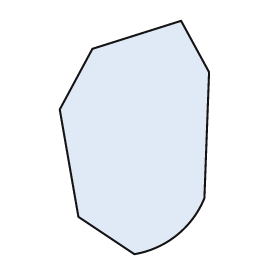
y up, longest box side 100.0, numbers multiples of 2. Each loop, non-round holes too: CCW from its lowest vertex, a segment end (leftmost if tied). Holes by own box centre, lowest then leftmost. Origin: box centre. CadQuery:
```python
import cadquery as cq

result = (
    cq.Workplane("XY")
    .moveTo(0.0, -50.0)
    .threePointArc((18.0, -42.0), (30.0, -26.0))
    .lineTo(32.0, 28.0)
    .lineTo(20.0, 50.0)
    .lineTo(-18.0, 38.0)
    .lineTo(-32.0, 12.0)
    .lineTo(-24.0, -34.0)
    .close()
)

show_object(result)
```